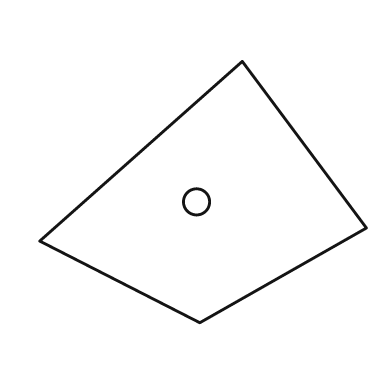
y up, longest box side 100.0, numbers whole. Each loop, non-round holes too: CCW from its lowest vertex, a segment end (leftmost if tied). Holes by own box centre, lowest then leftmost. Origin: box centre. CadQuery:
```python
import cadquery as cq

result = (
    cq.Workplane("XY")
    .moveTo(-1.0, -40.0)
    .lineTo(50.0, -11.0)
    .lineTo(12.0, 40.0)
    .lineTo(-50.0, -15.0)
    .close()
    .moveTo(-2.0, -3.0)
    .circle(4.0)
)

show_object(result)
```